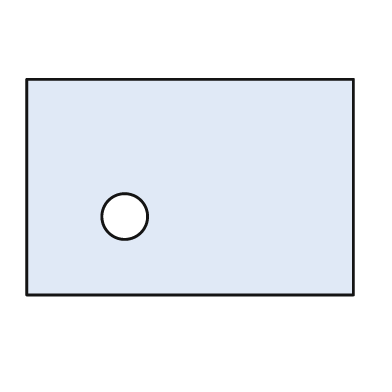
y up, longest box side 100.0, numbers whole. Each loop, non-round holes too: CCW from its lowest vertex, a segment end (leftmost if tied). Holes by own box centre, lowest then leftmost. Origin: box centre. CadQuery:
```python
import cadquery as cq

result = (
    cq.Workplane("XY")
    .moveTo(-50.0, -33.0)
    .lineTo(50.0, -33.0)
    .lineTo(50.0, 33.0)
    .lineTo(-50.0, 33.0)
    .close()
    .moveTo(-20.0, -9.0)
    .circle(7.0)
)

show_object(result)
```